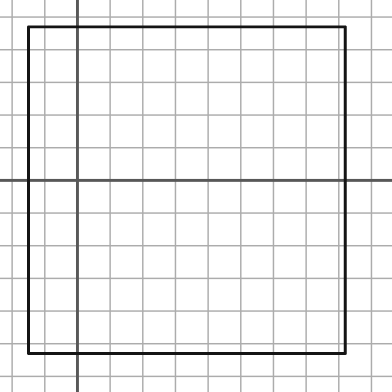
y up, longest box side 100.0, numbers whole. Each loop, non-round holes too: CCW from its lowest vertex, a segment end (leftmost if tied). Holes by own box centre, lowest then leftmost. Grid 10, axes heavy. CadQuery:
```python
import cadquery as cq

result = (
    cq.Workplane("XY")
    .moveTo(-15.0, -53.0)
    .lineTo(82.0, -53.0)
    .lineTo(82.0, 47.0)
    .lineTo(-15.0, 47.0)
    .close()
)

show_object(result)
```